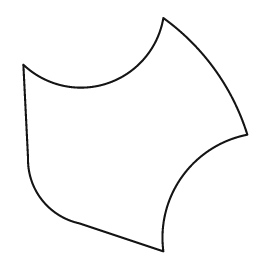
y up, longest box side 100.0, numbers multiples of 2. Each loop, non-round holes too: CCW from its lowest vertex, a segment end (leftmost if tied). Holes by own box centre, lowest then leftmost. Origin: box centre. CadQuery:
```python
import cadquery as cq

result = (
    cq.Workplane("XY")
    .moveTo(12.0, -50.0)
    .threePointArc((20.0, -18.0), (48.0, 0.0))
    .threePointArc((34.0, 28.0), (12.0, 50.0))
    .threePointArc((-12.0, 22.0), (-48.0, 30.0))
    .lineTo(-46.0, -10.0)
    .threePointArc((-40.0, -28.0), (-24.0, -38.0))
    .close()
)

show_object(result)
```